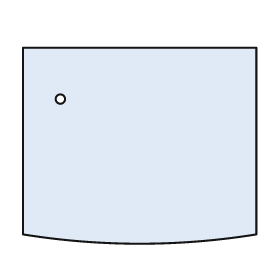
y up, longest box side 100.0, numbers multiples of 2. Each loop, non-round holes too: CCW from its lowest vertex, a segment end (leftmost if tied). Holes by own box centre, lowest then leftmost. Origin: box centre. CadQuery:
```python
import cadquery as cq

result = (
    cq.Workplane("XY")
    .moveTo(-50.0, -38.0)
    .threePointArc((0.0, -42.0), (50.0, -38.0))
    .lineTo(50.0, 42.0)
    .lineTo(-50.0, 42.0)
    .close()
    .moveTo(-34.0, 20.0)
    .circle(2.0)
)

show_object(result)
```